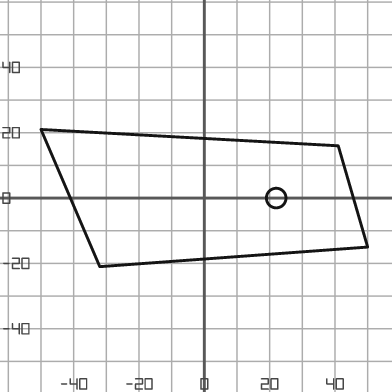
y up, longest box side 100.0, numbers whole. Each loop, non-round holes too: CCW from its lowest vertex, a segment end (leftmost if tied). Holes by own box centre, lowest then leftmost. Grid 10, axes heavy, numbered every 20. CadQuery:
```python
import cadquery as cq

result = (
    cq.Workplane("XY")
    .moveTo(-32.0, -21.0)
    .lineTo(50.0, -15.0)
    .lineTo(41.0, 16.0)
    .lineTo(-50.0, 21.0)
    .close()
    .moveTo(22.0, 0.0)
    .circle(3.0)
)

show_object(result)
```